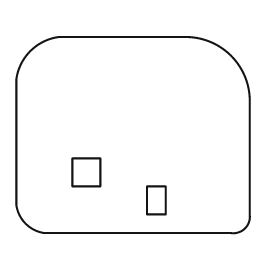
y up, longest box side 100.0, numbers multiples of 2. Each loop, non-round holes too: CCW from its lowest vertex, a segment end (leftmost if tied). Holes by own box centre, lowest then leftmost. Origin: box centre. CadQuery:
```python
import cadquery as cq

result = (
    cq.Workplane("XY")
    .moveTo(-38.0, -42.0)
    .lineTo(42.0, -42.0)
    .threePointArc((48.0, -40.0), (50.0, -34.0))
    .lineTo(50.0, 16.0)
    .threePointArc((42.0, 34.0), (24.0, 42.0))
    .lineTo(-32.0, 42.0)
    .threePointArc((-44.0, 36.0), (-50.0, 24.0))
    .lineTo(-50.0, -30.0)
    .threePointArc((-46.0, -38.0), (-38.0, -42.0))
    .close()
    .moveTo(6.0, -34.0)
    .lineTo(14.0, -34.0)
    .lineTo(14.0, -22.0)
    .lineTo(6.0, -22.0)
    .close()
    .moveTo(-26.0, -22.0)
    .lineTo(-14.0, -22.0)
    .lineTo(-14.0, -10.0)
    .lineTo(-26.0, -10.0)
    .close()
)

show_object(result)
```